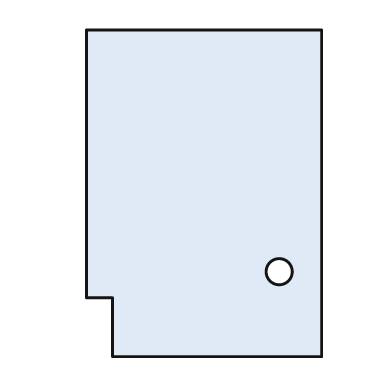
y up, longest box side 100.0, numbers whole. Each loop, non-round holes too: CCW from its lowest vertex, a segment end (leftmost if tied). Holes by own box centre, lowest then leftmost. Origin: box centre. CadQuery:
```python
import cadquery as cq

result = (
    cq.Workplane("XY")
    .moveTo(-28.0, -50.0)
    .lineTo(36.0, -50.0)
    .lineTo(36.0, 50.0)
    .lineTo(-36.0, 50.0)
    .lineTo(-36.0, -32.0)
    .lineTo(-28.0, -32.0)
    .close()
    .moveTo(23.0, -24.0)
    .circle(4.0)
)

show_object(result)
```